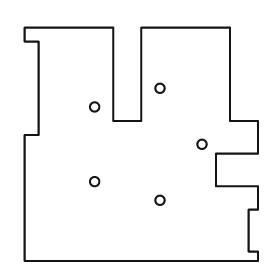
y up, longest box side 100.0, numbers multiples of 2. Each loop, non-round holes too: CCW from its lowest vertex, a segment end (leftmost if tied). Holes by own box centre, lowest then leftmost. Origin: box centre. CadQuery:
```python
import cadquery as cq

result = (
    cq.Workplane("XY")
    .moveTo(-50.0, -50.0)
    .lineTo(50.0, -50.0)
    .lineTo(50.0, -46.0)
    .lineTo(46.0, -46.0)
    .lineTo(46.0, -28.0)
    .lineTo(50.0, -28.0)
    .lineTo(50.0, -18.0)
    .lineTo(32.0, -18.0)
    .lineTo(32.0, -4.0)
    .lineTo(50.0, -4.0)
    .lineTo(50.0, 10.0)
    .lineTo(38.0, 10.0)
    .lineTo(38.0, 50.0)
    .lineTo(0.0, 50.0)
    .lineTo(0.0, 10.0)
    .lineTo(-12.0, 10.0)
    .lineTo(-12.0, 50.0)
    .lineTo(-50.0, 50.0)
    .lineTo(-50.0, 44.0)
    .lineTo(-44.0, 44.0)
    .lineTo(-44.0, 4.0)
    .lineTo(-50.0, 4.0)
    .close()
    .moveTo(8.0, -24.0)
    .circle(2.0)
    .moveTo(-20.0, -16.0)
    .circle(2.0)
    .moveTo(26.0, 0.0)
    .circle(2.0)
    .moveTo(-20.0, 16.0)
    .circle(2.0)
    .moveTo(8.0, 24.0)
    .circle(2.0)
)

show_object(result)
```